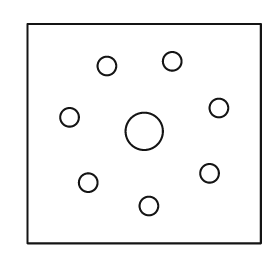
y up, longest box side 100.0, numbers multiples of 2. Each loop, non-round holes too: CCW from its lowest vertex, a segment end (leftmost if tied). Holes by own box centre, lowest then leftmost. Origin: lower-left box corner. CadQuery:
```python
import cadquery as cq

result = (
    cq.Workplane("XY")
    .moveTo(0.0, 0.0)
    .lineTo(100.0, 0.0)
    .lineTo(100.0, 94.0)
    .lineTo(0.0, 94.0)
    .close()
    .moveTo(52.0, 16.0)
    .circle(4.0)
    .moveTo(26.0, 26.0)
    .circle(4.0)
    .moveTo(78.0, 30.0)
    .circle(4.0)
    .moveTo(50.0, 48.0)
    .circle(8.0)
    .moveTo(18.0, 54.0)
    .circle(4.0)
    .moveTo(82.0, 58.0)
    .circle(4.0)
    .moveTo(34.0, 76.0)
    .circle(4.0)
    .moveTo(62.0, 78.0)
    .circle(4.0)
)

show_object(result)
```